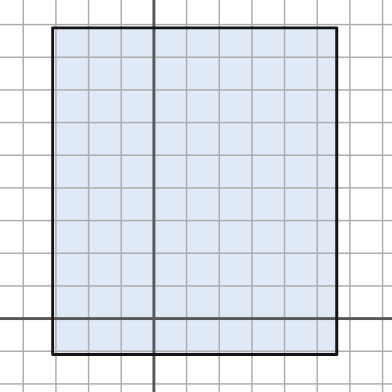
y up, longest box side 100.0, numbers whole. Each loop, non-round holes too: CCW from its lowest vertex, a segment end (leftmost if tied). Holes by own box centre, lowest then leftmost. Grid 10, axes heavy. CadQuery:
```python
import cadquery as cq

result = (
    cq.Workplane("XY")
    .moveTo(-31.0, -11.0)
    .lineTo(56.0, -11.0)
    .lineTo(56.0, 89.0)
    .lineTo(-31.0, 89.0)
    .close()
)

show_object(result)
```